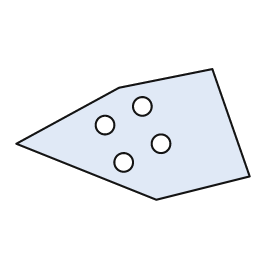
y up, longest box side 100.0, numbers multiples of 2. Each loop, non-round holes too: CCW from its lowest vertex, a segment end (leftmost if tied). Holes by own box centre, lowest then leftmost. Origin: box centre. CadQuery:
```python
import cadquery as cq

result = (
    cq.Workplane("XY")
    .moveTo(10.0, -28.0)
    .lineTo(50.0, -18.0)
    .lineTo(34.0, 28.0)
    .lineTo(-6.0, 20.0)
    .lineTo(-50.0, -4.0)
    .close()
    .moveTo(-4.0, -12.0)
    .circle(4.0)
    .moveTo(12.0, -4.0)
    .circle(4.0)
    .moveTo(-12.0, 4.0)
    .circle(4.0)
    .moveTo(4.0, 12.0)
    .circle(4.0)
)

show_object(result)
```